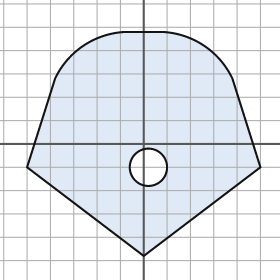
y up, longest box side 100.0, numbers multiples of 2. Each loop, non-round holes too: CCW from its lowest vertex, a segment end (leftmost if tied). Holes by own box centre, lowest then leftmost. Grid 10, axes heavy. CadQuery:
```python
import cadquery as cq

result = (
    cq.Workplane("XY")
    .moveTo(0.0, -48.0)
    .lineTo(50.0, -10.0)
    .lineTo(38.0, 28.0)
    .threePointArc((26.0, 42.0), (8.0, 48.0))
    .lineTo(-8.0, 48.0)
    .threePointArc((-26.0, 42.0), (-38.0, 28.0))
    .lineTo(-50.0, -10.0)
    .close()
    .moveTo(2.0, -10.0)
    .circle(8.0)
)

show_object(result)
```